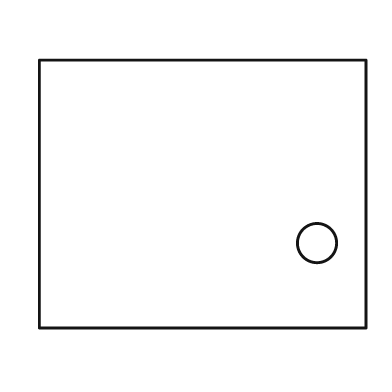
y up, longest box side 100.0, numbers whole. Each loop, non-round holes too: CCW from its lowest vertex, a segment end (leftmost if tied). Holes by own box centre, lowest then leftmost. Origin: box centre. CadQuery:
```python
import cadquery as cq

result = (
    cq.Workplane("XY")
    .moveTo(-50.0, -41.0)
    .lineTo(50.0, -41.0)
    .lineTo(50.0, 41.0)
    .lineTo(-50.0, 41.0)
    .close()
    .moveTo(35.0, -15.0)
    .circle(6.0)
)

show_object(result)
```